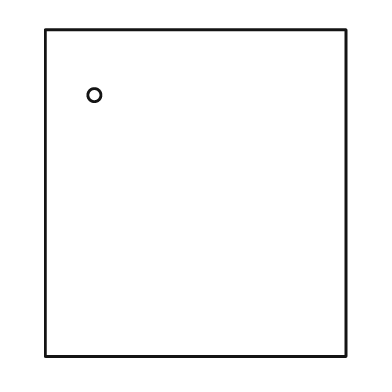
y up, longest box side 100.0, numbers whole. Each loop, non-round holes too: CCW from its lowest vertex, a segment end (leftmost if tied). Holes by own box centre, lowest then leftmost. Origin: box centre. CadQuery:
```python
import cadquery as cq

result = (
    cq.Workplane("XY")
    .moveTo(-46.0, -50.0)
    .lineTo(46.0, -50.0)
    .lineTo(46.0, 50.0)
    .lineTo(-46.0, 50.0)
    .close()
    .moveTo(-31.0, 30.0)
    .circle(2.0)
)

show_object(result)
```